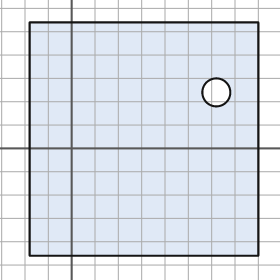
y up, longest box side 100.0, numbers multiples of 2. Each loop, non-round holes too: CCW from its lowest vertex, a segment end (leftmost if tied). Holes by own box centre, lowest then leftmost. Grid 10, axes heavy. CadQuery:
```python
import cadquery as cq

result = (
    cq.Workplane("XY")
    .moveTo(-18.0, -46.0)
    .lineTo(80.0, -46.0)
    .lineTo(80.0, 54.0)
    .lineTo(-18.0, 54.0)
    .close()
    .moveTo(62.0, 24.0)
    .circle(6.0)
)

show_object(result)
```